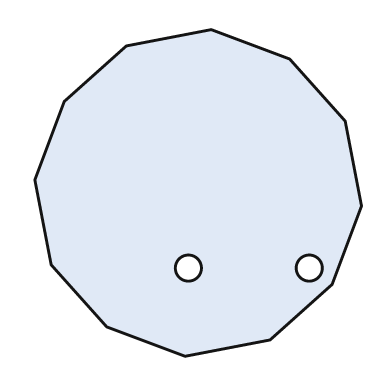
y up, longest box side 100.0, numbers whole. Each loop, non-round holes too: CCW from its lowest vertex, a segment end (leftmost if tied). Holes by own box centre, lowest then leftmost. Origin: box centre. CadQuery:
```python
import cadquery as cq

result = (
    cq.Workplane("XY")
    .moveTo(-4.0, -50.0)
    .lineTo(22.0, -45.0)
    .lineTo(41.0, -28.0)
    .lineTo(50.0, -4.0)
    .lineTo(45.0, 22.0)
    .lineTo(28.0, 41.0)
    .lineTo(4.0, 50.0)
    .lineTo(-22.0, 45.0)
    .lineTo(-41.0, 28.0)
    .lineTo(-50.0, 4.0)
    .lineTo(-45.0, -22.0)
    .lineTo(-28.0, -41.0)
    .close()
    .moveTo(-3.0, -23.0)
    .circle(4.0)
    .moveTo(34.0, -23.0)
    .circle(4.0)
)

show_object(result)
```